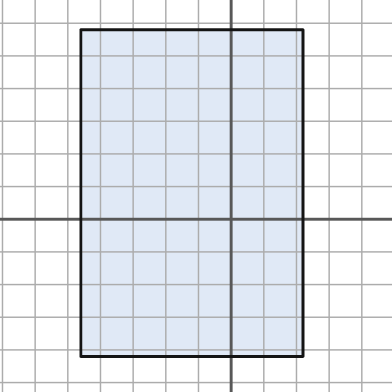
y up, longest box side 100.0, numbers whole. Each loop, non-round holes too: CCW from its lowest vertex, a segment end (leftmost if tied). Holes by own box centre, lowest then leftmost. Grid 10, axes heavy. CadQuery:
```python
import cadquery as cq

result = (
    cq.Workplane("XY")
    .moveTo(-46.0, -42.0)
    .lineTo(22.0, -42.0)
    .lineTo(22.0, 58.0)
    .lineTo(-46.0, 58.0)
    .close()
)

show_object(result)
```